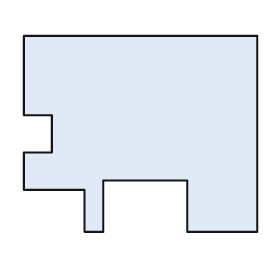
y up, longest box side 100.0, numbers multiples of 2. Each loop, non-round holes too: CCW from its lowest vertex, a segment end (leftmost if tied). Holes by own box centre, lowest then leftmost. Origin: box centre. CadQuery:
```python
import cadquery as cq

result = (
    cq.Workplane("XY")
    .moveTo(-24.0, -42.0)
    .lineTo(-16.0, -42.0)
    .lineTo(-16.0, -20.0)
    .lineTo(20.0, -20.0)
    .lineTo(20.0, -42.0)
    .lineTo(50.0, -42.0)
    .lineTo(50.0, 42.0)
    .lineTo(-50.0, 42.0)
    .lineTo(-50.0, 8.0)
    .lineTo(-38.0, 8.0)
    .lineTo(-38.0, -8.0)
    .lineTo(-50.0, -8.0)
    .lineTo(-50.0, -24.0)
    .lineTo(-24.0, -24.0)
    .close()
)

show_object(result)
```